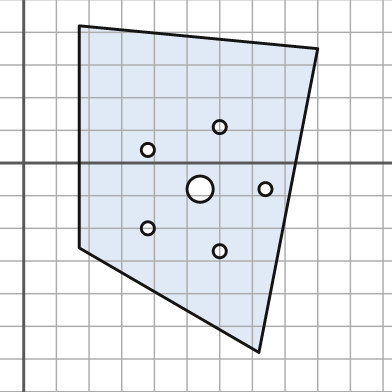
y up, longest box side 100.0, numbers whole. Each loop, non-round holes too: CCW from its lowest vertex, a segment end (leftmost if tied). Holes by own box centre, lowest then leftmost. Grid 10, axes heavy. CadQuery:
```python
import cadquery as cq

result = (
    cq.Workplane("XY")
    .moveTo(72.0, -58.0)
    .lineTo(90.0, 35.0)
    .lineTo(17.0, 42.0)
    .lineTo(17.0, -26.0)
    .close()
    .moveTo(60.0, -27.0)
    .circle(2.0)
    .moveTo(38.0, -20.0)
    .circle(2.0)
    .moveTo(54.0, -8.0)
    .circle(4.0)
    .moveTo(74.0, -8.0)
    .circle(2.0)
    .moveTo(38.0, 4.0)
    .circle(2.0)
    .moveTo(60.0, 11.0)
    .circle(2.0)
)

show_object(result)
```